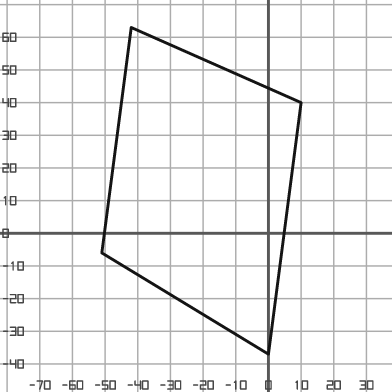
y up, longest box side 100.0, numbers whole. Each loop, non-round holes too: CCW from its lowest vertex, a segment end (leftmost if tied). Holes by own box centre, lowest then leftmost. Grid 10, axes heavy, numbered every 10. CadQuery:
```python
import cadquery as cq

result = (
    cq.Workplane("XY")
    .moveTo(0.0, -37.0)
    .lineTo(10.0, 40.0)
    .lineTo(-42.0, 63.0)
    .lineTo(-51.0, -6.0)
    .close()
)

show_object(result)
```